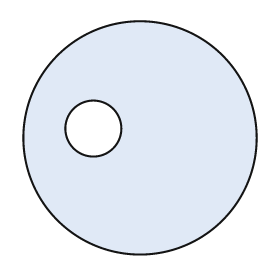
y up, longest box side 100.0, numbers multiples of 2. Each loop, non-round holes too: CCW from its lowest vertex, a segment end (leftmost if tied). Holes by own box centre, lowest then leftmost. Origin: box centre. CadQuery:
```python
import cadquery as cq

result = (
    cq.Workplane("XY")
    .moveTo(0.0, 0.0)
    .circle(50.0)
    .moveTo(-20.0, 4.0)
    .circle(12.0)
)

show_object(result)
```